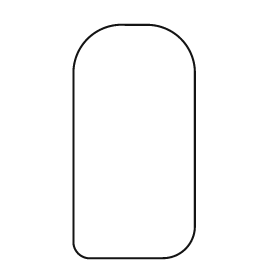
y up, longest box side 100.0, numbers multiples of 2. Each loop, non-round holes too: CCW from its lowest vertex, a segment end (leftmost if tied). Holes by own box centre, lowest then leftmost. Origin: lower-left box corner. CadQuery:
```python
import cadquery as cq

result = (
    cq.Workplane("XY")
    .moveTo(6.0, 0.0)
    .lineTo(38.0, 0.0)
    .threePointArc((48.0, 4.0), (52.0, 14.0))
    .lineTo(52.0, 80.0)
    .threePointArc((46.0, 94.0), (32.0, 100.0))
    .lineTo(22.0, 100.0)
    .threePointArc((6.0, 94.0), (0.0, 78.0))
    .lineTo(0.0, 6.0)
    .threePointArc((2.0, 2.0), (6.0, 0.0))
    .close()
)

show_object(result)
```